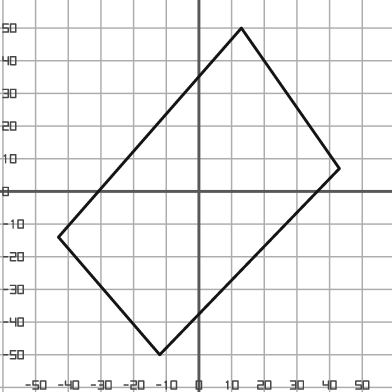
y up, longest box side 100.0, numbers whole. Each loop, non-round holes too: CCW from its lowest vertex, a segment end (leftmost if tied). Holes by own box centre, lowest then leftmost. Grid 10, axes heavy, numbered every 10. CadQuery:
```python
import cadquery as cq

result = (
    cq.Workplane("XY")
    .moveTo(-12.0, -50.0)
    .lineTo(43.0, 7.0)
    .lineTo(13.0, 50.0)
    .lineTo(-43.0, -14.0)
    .close()
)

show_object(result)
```